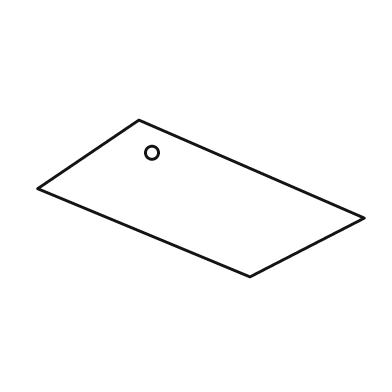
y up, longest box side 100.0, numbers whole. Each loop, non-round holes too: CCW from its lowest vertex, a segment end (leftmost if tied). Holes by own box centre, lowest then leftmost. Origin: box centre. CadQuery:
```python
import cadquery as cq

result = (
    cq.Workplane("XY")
    .moveTo(15.0, -24.0)
    .lineTo(50.0, -6.0)
    .lineTo(-19.0, 24.0)
    .lineTo(-50.0, 3.0)
    .close()
    .moveTo(-15.0, 14.0)
    .circle(2.0)
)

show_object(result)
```